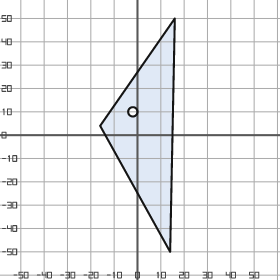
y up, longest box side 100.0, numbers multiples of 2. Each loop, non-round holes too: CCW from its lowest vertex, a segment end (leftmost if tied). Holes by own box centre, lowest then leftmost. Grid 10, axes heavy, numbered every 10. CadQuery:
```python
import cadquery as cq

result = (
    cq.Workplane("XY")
    .moveTo(14.0, -50.0)
    .lineTo(16.0, 50.0)
    .lineTo(-16.0, 4.0)
    .close()
    .moveTo(-2.0, 10.0)
    .circle(2.0)
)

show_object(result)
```